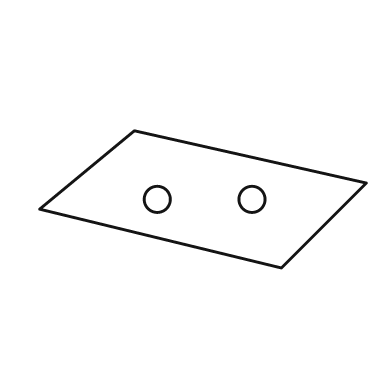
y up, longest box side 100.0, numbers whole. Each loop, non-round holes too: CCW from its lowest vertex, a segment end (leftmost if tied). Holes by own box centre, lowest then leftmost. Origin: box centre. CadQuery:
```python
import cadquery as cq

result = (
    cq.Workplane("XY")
    .moveTo(24.0, -21.0)
    .lineTo(50.0, 5.0)
    .lineTo(-21.0, 21.0)
    .lineTo(-50.0, -3.0)
    .close()
    .moveTo(-14.0, 0.0)
    .circle(4.0)
    .moveTo(15.0, 0.0)
    .circle(4.0)
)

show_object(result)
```